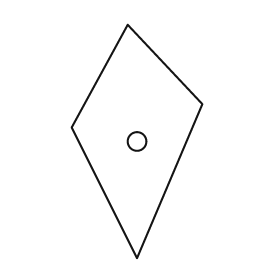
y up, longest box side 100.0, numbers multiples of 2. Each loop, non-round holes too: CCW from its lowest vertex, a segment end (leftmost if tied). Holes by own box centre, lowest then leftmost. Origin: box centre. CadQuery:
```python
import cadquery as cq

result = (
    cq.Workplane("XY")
    .moveTo(0.0, -50.0)
    .lineTo(28.0, 16.0)
    .lineTo(-4.0, 50.0)
    .lineTo(-28.0, 6.0)
    .close()
    .moveTo(0.0, 0.0)
    .circle(4.0)
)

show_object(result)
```